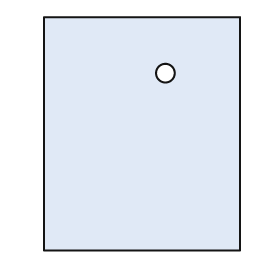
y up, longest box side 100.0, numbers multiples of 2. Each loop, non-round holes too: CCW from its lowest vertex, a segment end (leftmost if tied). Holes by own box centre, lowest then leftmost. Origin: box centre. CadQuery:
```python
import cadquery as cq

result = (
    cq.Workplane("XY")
    .moveTo(-42.0, -50.0)
    .lineTo(42.0, -50.0)
    .lineTo(42.0, 50.0)
    .lineTo(-42.0, 50.0)
    .close()
    .moveTo(10.0, 26.0)
    .circle(4.0)
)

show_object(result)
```